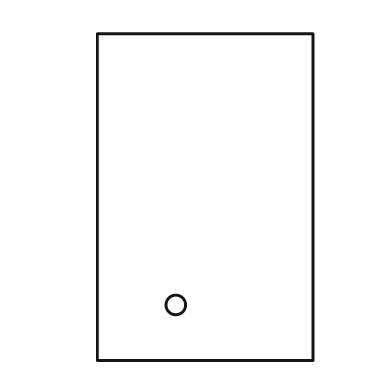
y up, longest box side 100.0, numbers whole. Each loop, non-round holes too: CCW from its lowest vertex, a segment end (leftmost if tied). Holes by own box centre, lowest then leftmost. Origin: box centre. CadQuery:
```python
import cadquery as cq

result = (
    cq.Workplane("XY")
    .moveTo(-33.0, -50.0)
    .lineTo(33.0, -50.0)
    .lineTo(33.0, 50.0)
    .lineTo(-33.0, 50.0)
    .close()
    .moveTo(-9.0, -33.0)
    .circle(3.0)
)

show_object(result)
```